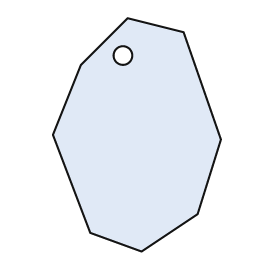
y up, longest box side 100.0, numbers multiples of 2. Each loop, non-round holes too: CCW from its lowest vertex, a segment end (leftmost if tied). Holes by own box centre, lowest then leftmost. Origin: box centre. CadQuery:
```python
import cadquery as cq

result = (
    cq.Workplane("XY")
    .moveTo(2.0, -50.0)
    .lineTo(26.0, -34.0)
    .lineTo(36.0, -2.0)
    .lineTo(20.0, 44.0)
    .lineTo(-4.0, 50.0)
    .lineTo(-24.0, 30.0)
    .lineTo(-36.0, 0.0)
    .lineTo(-20.0, -42.0)
    .close()
    .moveTo(-6.0, 34.0)
    .circle(4.0)
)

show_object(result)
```